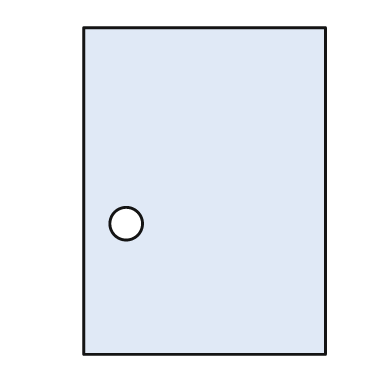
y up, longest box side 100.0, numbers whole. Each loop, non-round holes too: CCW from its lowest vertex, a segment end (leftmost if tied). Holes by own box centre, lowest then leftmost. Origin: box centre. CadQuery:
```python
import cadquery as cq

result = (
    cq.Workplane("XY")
    .moveTo(-37.0, -50.0)
    .lineTo(37.0, -50.0)
    .lineTo(37.0, 50.0)
    .lineTo(-37.0, 50.0)
    .close()
    .moveTo(-24.0, -10.0)
    .circle(5.0)
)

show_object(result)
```